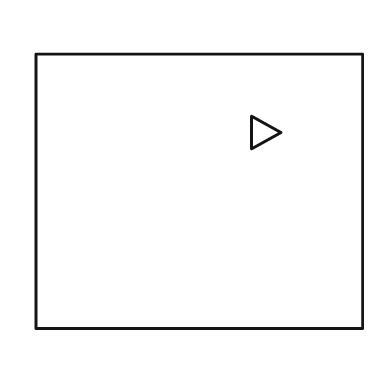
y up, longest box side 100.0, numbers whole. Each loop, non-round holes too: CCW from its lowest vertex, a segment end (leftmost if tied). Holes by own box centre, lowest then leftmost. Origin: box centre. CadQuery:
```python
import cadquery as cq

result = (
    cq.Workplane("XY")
    .moveTo(-50.0, -42.0)
    .lineTo(50.0, -42.0)
    .lineTo(50.0, 42.0)
    .lineTo(-50.0, 42.0)
    .close()
    .moveTo(16.0, 13.0)
    .lineTo(25.0, 18.0)
    .lineTo(16.0, 23.0)
    .close()
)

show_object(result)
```